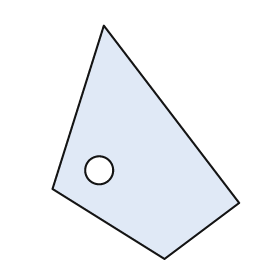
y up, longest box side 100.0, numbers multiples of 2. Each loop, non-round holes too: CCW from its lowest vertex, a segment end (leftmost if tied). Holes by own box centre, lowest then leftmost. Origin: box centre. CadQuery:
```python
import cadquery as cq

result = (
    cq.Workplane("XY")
    .moveTo(8.0, -50.0)
    .lineTo(40.0, -26.0)
    .lineTo(-18.0, 50.0)
    .lineTo(-40.0, -20.0)
    .close()
    .moveTo(-20.0, -12.0)
    .circle(6.0)
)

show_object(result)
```